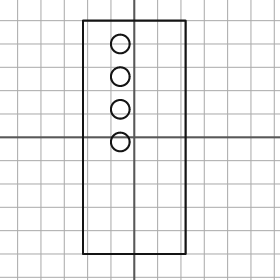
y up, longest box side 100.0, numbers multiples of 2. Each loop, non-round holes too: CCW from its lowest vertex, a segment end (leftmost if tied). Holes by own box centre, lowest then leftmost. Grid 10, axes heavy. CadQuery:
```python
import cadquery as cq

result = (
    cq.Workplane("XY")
    .moveTo(-22.0, -50.0)
    .lineTo(22.0, -50.0)
    .lineTo(22.0, 50.0)
    .lineTo(-22.0, 50.0)
    .close()
    .moveTo(-6.0, -2.0)
    .circle(4.0)
    .moveTo(-6.0, 12.0)
    .circle(4.0)
    .moveTo(-6.0, 26.0)
    .circle(4.0)
    .moveTo(-6.0, 40.0)
    .circle(4.0)
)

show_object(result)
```